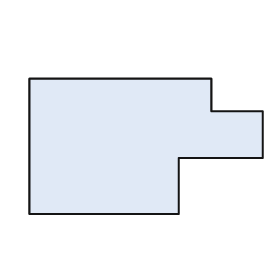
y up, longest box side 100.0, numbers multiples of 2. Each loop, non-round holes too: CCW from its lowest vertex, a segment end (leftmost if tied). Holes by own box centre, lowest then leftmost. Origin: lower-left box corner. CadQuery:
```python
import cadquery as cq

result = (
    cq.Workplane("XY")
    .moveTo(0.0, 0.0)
    .lineTo(64.0, 0.0)
    .lineTo(64.0, 24.0)
    .lineTo(100.0, 24.0)
    .lineTo(100.0, 44.0)
    .lineTo(78.0, 44.0)
    .lineTo(78.0, 58.0)
    .lineTo(0.0, 58.0)
    .close()
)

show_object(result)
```